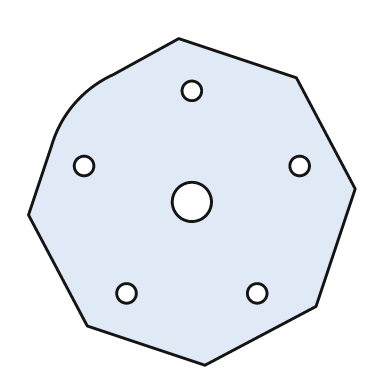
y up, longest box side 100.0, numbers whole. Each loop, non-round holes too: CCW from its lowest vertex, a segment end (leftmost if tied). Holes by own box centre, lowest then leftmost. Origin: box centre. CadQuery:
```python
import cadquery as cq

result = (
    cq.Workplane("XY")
    .moveTo(4.0, -50.0)
    .lineTo(38.0, -32.0)
    .lineTo(50.0, 4.0)
    .lineTo(32.0, 38.0)
    .lineTo(-4.0, 50.0)
    .lineTo(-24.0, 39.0)
    .threePointArc((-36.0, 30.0), (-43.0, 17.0))
    .lineTo(-50.0, -4.0)
    .lineTo(-32.0, -38.0)
    .close()
    .moveTo(-20.0, -28.0)
    .circle(3.0)
    .moveTo(20.0, -28.0)
    .circle(3.0)
    .moveTo(0.0, 0.0)
    .circle(6.0)
    .moveTo(-33.0, 11.0)
    .circle(3.0)
    .moveTo(33.0, 11.0)
    .circle(3.0)
    .moveTo(0.0, 34.0)
    .circle(3.0)
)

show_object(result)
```